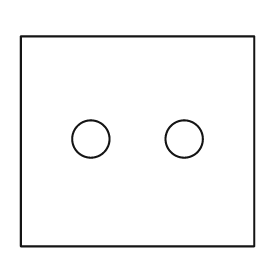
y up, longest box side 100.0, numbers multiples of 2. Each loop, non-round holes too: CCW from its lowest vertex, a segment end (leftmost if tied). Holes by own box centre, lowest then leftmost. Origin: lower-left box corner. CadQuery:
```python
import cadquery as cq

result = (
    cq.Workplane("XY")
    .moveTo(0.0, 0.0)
    .lineTo(100.0, 0.0)
    .lineTo(100.0, 90.0)
    .lineTo(0.0, 90.0)
    .close()
    .moveTo(30.0, 46.0)
    .circle(8.0)
    .moveTo(70.0, 46.0)
    .circle(8.0)
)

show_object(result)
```